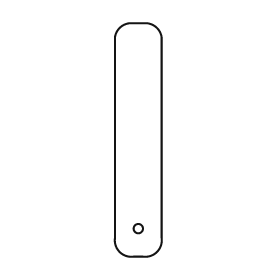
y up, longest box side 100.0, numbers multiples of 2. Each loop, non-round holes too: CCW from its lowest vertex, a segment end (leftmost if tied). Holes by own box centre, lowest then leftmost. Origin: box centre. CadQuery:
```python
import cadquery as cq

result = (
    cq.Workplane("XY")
    .moveTo(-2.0, -50.0)
    .lineTo(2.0, -50.0)
    .threePointArc((8.0, -48.0), (10.0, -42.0))
    .lineTo(10.0, 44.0)
    .threePointArc((8.0, 48.0), (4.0, 50.0))
    .lineTo(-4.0, 50.0)
    .threePointArc((-8.0, 48.0), (-10.0, 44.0))
    .lineTo(-10.0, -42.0)
    .threePointArc((-8.0, -48.0), (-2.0, -50.0))
    .close()
    .moveTo(0.0, -38.0)
    .circle(2.0)
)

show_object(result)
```